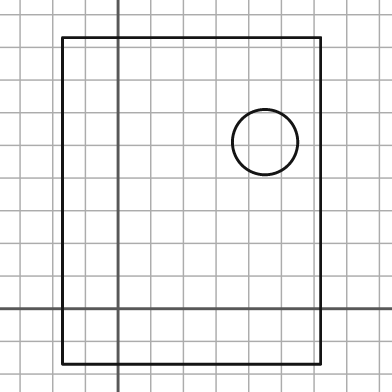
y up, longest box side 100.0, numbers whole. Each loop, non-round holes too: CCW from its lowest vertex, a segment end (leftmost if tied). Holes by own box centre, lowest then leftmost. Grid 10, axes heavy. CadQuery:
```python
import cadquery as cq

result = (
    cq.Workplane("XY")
    .moveTo(-17.0, -17.0)
    .lineTo(62.0, -17.0)
    .lineTo(62.0, 83.0)
    .lineTo(-17.0, 83.0)
    .close()
    .moveTo(45.0, 51.0)
    .circle(10.0)
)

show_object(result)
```